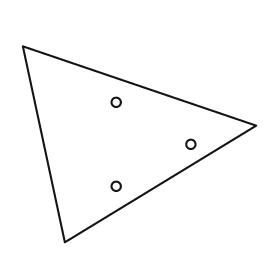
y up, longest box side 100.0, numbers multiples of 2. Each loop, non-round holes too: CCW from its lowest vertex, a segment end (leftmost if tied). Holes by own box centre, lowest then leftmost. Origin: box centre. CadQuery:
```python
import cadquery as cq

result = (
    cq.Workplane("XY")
    .moveTo(-32.0, -42.0)
    .lineTo(50.0, 8.0)
    .lineTo(-50.0, 42.0)
    .close()
    .moveTo(-10.0, -18.0)
    .circle(2.0)
    .moveTo(22.0, 0.0)
    .circle(2.0)
    .moveTo(-10.0, 18.0)
    .circle(2.0)
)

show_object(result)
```